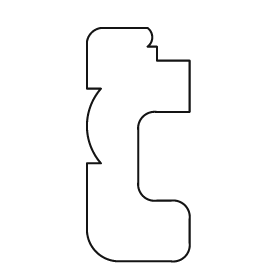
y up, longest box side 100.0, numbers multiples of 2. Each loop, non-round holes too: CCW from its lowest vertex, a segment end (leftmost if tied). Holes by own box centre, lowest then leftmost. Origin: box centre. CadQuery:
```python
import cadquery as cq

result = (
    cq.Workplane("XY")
    .moveTo(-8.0, -50.0)
    .lineTo(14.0, -50.0)
    .threePointArc((20.0, -48.0), (22.0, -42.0))
    .lineTo(22.0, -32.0)
    .threePointArc((20.0, -26.0), (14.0, -24.0))
    .lineTo(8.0, -24.0)
    .threePointArc((2.0, -22.0), (0.0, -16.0))
    .lineTo(0.0, 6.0)
    .threePointArc((2.0, 12.0), (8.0, 14.0))
    .lineTo(22.0, 14.0)
    .lineTo(22.0, 36.0)
    .lineTo(8.0, 36.0)
    .lineTo(8.0, 42.0)
    .lineTo(4.0, 42.0)
    .threePointArc((6.0, 46.0), (4.0, 50.0))
    .lineTo(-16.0, 50.0)
    .threePointArc((-20.0, 48.0), (-22.0, 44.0))
    .lineTo(-22.0, 24.0)
    .lineTo(-16.0, 24.0)
    .threePointArc((-22.0, 8.0), (-16.0, -8.0))
    .lineTo(-22.0, -8.0)
    .lineTo(-22.0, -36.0)
    .threePointArc((-18.0, -46.0), (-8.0, -50.0))
    .close()
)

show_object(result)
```